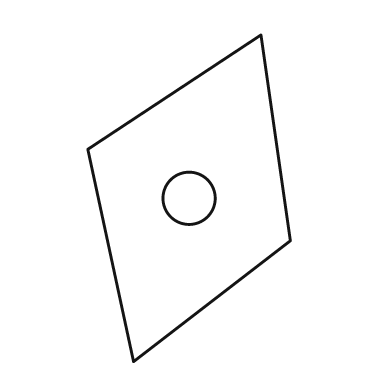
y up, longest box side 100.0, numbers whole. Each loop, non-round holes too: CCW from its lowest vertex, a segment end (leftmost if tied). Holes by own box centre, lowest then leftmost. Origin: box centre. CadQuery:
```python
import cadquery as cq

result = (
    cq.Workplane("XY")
    .moveTo(-17.0, -50.0)
    .lineTo(31.0, -13.0)
    .lineTo(22.0, 50.0)
    .lineTo(-31.0, 15.0)
    .close()
    .moveTo(0.0, 0.0)
    .circle(8.0)
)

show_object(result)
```